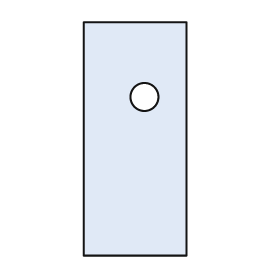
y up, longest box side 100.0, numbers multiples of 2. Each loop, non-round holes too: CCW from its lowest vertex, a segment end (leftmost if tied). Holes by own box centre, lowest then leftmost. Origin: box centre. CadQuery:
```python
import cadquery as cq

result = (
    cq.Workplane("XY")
    .moveTo(-22.0, -50.0)
    .lineTo(22.0, -50.0)
    .lineTo(22.0, 50.0)
    .lineTo(-22.0, 50.0)
    .close()
    .moveTo(4.0, 18.0)
    .circle(6.0)
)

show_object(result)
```